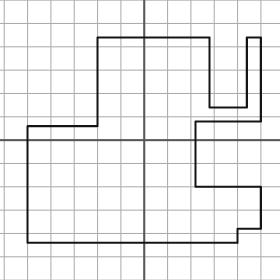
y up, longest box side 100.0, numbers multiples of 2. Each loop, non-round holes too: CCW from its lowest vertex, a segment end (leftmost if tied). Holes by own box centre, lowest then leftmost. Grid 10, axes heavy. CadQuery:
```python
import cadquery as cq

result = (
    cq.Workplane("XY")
    .moveTo(-50.0, -44.0)
    .lineTo(40.0, -44.0)
    .lineTo(40.0, -38.0)
    .lineTo(50.0, -38.0)
    .lineTo(50.0, -20.0)
    .lineTo(22.0, -20.0)
    .lineTo(22.0, 8.0)
    .lineTo(50.0, 8.0)
    .lineTo(50.0, 44.0)
    .lineTo(44.0, 44.0)
    .lineTo(44.0, 14.0)
    .lineTo(28.0, 14.0)
    .lineTo(28.0, 44.0)
    .lineTo(-20.0, 44.0)
    .lineTo(-20.0, 6.0)
    .lineTo(-50.0, 6.0)
    .close()
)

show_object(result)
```